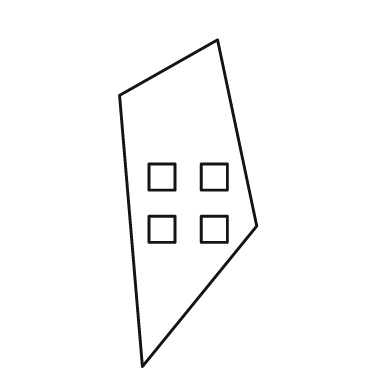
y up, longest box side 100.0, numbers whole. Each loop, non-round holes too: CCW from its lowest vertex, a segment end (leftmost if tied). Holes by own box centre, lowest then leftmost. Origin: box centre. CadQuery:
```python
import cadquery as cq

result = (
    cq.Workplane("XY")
    .moveTo(-14.0, -50.0)
    .lineTo(21.0, -7.0)
    .lineTo(9.0, 50.0)
    .lineTo(-21.0, 33.0)
    .close()
    .moveTo(-12.0, -12.0)
    .lineTo(-4.0, -12.0)
    .lineTo(-4.0, -4.0)
    .lineTo(-12.0, -4.0)
    .close()
    .moveTo(4.0, -12.0)
    .lineTo(12.0, -12.0)
    .lineTo(12.0, -4.0)
    .lineTo(4.0, -4.0)
    .close()
    .moveTo(-12.0, 4.0)
    .lineTo(-4.0, 4.0)
    .lineTo(-4.0, 12.0)
    .lineTo(-12.0, 12.0)
    .close()
    .moveTo(4.0, 4.0)
    .lineTo(12.0, 4.0)
    .lineTo(12.0, 12.0)
    .lineTo(4.0, 12.0)
    .close()
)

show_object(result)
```